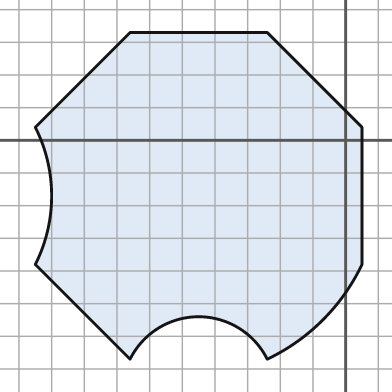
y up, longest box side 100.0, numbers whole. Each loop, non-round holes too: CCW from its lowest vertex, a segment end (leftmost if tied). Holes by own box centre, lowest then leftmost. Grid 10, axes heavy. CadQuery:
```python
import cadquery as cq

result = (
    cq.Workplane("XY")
    .moveTo(-66.0, -67.0)
    .threePointArc((-45.0, -54.0), (-24.0, -67.0))
    .threePointArc((-7.0, -55.0), (5.0, -38.0))
    .lineTo(5.0, 4.0)
    .lineTo(-24.0, 33.0)
    .lineTo(-66.0, 33.0)
    .lineTo(-95.0, 4.0)
    .threePointArc((-90.0, -17.0), (-95.0, -38.0))
    .close()
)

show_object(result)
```